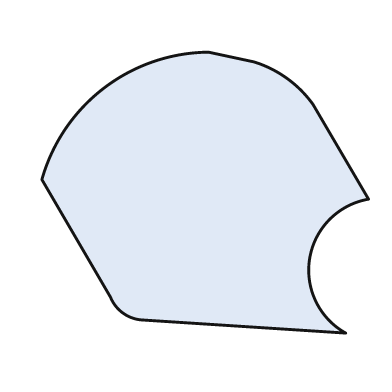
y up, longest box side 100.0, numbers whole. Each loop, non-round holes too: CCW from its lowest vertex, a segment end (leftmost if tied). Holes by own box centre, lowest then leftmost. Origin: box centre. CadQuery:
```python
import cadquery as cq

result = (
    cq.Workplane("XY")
    .moveTo(43.0, -43.0)
    .threePointArc((32.0, -20.0), (50.0, -2.0))
    .lineTo(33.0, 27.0)
    .threePointArc((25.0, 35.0), (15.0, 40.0))
    .lineTo(1.0, 43.0)
    .threePointArc((-31.0, 32.0), (-50.0, 4.0))
    .lineTo(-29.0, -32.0)
    .threePointArc((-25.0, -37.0), (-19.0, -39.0))
    .close()
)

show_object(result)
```